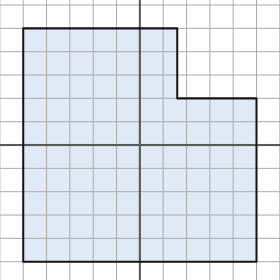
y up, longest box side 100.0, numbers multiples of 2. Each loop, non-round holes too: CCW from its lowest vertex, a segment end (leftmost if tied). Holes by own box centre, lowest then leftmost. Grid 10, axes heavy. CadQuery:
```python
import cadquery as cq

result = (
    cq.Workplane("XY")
    .moveTo(-50.0, -50.0)
    .lineTo(50.0, -50.0)
    .lineTo(50.0, 20.0)
    .lineTo(16.0, 20.0)
    .lineTo(16.0, 50.0)
    .lineTo(-50.0, 50.0)
    .close()
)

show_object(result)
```